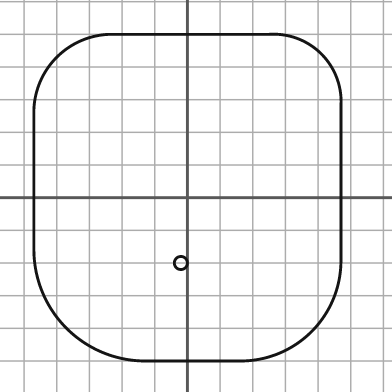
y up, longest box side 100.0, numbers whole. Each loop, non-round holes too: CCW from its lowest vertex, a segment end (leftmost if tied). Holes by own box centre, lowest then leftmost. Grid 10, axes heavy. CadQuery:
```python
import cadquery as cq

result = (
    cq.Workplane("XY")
    .moveTo(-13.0, -50.0)
    .lineTo(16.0, -50.0)
    .threePointArc((38.0, -41.0), (47.0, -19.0))
    .lineTo(47.0, 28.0)
    .threePointArc((41.0, 44.0), (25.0, 50.0))
    .lineTo(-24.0, 50.0)
    .threePointArc((-40.0, 43.0), (-47.0, 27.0))
    .lineTo(-47.0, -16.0)
    .threePointArc((-37.0, -40.0), (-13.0, -50.0))
    .close()
    .moveTo(-2.0, -20.0)
    .circle(2.0)
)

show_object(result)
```